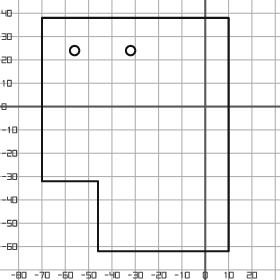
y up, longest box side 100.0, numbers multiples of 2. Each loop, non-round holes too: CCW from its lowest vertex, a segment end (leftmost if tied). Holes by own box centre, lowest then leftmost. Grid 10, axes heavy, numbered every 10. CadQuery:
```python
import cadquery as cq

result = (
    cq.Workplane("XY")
    .moveTo(-46.0, -62.0)
    .lineTo(10.0, -62.0)
    .lineTo(10.0, 38.0)
    .lineTo(-70.0, 38.0)
    .lineTo(-70.0, -32.0)
    .lineTo(-46.0, -32.0)
    .close()
    .moveTo(-56.0, 24.0)
    .circle(2.0)
    .moveTo(-32.0, 24.0)
    .circle(2.0)
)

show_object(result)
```